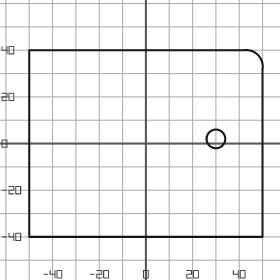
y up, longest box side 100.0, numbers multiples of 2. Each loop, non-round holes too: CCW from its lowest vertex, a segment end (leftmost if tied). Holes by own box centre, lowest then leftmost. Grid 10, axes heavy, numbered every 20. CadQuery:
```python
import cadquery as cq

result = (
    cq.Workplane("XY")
    .moveTo(-50.0, -40.0)
    .lineTo(50.0, -40.0)
    .lineTo(50.0, 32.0)
    .threePointArc((48.0, 38.0), (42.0, 40.0))
    .lineTo(-50.0, 40.0)
    .close()
    .moveTo(30.0, 2.0)
    .circle(4.0)
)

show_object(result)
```